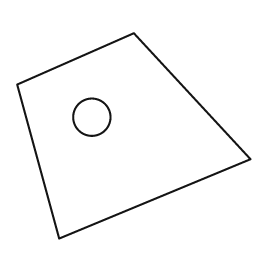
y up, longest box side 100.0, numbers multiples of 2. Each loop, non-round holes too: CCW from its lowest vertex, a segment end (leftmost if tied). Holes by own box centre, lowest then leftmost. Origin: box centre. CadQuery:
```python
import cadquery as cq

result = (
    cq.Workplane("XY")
    .moveTo(-32.0, -44.0)
    .lineTo(50.0, -10.0)
    .lineTo(0.0, 44.0)
    .lineTo(-50.0, 22.0)
    .close()
    .moveTo(-18.0, 8.0)
    .circle(8.0)
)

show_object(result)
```